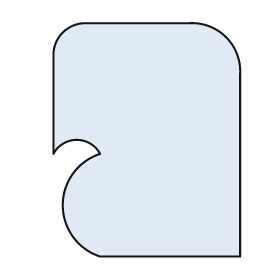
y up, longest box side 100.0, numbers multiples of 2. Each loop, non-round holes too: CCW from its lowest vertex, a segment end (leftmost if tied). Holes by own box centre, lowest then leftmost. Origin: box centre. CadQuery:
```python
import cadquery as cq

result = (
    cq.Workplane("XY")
    .moveTo(-20.0, -50.0)
    .lineTo(40.0, -50.0)
    .lineTo(40.0, 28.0)
    .threePointArc((34.0, 44.0), (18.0, 50.0))
    .lineTo(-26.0, 50.0)
    .threePointArc((-36.0, 46.0), (-40.0, 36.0))
    .lineTo(-40.0, -6.0)
    .threePointArc((-30.0, 0.0), (-20.0, -6.0))
    .threePointArc((-36.0, -28.0), (-20.0, -50.0))
    .close()
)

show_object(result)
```